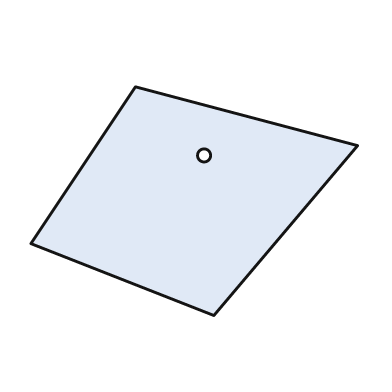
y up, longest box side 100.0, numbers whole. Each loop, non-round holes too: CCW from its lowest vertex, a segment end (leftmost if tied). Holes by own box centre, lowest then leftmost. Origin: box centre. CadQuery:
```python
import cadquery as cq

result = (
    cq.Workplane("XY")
    .moveTo(6.0, -35.0)
    .lineTo(50.0, 17.0)
    .lineTo(-18.0, 35.0)
    .lineTo(-50.0, -13.0)
    .close()
    .moveTo(3.0, 14.0)
    .circle(2.0)
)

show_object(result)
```